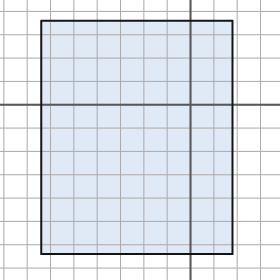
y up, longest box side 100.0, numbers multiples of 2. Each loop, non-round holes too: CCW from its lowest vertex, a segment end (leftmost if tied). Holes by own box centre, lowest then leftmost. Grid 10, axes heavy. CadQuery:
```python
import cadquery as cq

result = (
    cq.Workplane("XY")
    .moveTo(-64.0, -64.0)
    .lineTo(18.0, -64.0)
    .lineTo(18.0, 36.0)
    .lineTo(-64.0, 36.0)
    .close()
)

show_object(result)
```